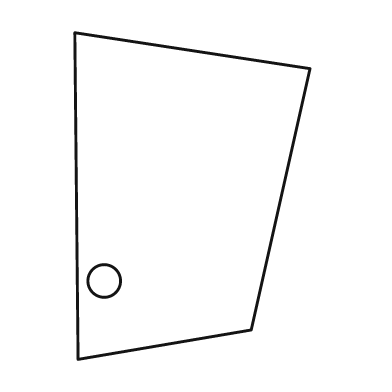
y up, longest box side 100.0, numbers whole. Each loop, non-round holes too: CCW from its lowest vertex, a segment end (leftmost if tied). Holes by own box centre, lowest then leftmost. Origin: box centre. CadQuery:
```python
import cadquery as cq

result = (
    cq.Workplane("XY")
    .moveTo(-35.0, -50.0)
    .lineTo(18.0, -41.0)
    .lineTo(36.0, 39.0)
    .lineTo(-36.0, 50.0)
    .close()
    .moveTo(-27.0, -26.0)
    .circle(5.0)
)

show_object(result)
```